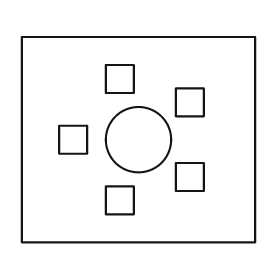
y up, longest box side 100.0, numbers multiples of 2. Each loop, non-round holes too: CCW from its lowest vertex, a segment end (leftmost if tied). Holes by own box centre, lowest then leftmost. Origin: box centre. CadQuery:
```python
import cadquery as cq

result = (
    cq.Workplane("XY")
    .moveTo(-50.0, -44.0)
    .lineTo(50.0, -44.0)
    .lineTo(50.0, 44.0)
    .lineTo(-50.0, 44.0)
    .close()
    .moveTo(-14.0, -32.0)
    .lineTo(-2.0, -32.0)
    .lineTo(-2.0, -20.0)
    .lineTo(-14.0, -20.0)
    .close()
    .moveTo(16.0, -22.0)
    .lineTo(28.0, -22.0)
    .lineTo(28.0, -10.0)
    .lineTo(16.0, -10.0)
    .close()
    .moveTo(-34.0, -6.0)
    .lineTo(-22.0, -6.0)
    .lineTo(-22.0, 6.0)
    .lineTo(-34.0, 6.0)
    .close()
    .moveTo(0.0, 0.0)
    .circle(14.0)
    .moveTo(16.0, 10.0)
    .lineTo(28.0, 10.0)
    .lineTo(28.0, 22.0)
    .lineTo(16.0, 22.0)
    .close()
    .moveTo(-14.0, 20.0)
    .lineTo(-2.0, 20.0)
    .lineTo(-2.0, 32.0)
    .lineTo(-14.0, 32.0)
    .close()
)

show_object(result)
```